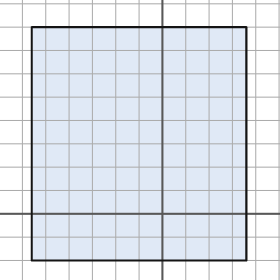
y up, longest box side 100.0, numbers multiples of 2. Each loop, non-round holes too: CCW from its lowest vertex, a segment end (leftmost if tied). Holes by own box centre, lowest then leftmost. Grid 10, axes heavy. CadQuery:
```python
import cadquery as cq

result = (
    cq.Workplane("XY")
    .moveTo(-56.0, -20.0)
    .lineTo(36.0, -20.0)
    .lineTo(36.0, 80.0)
    .lineTo(-56.0, 80.0)
    .close()
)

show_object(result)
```